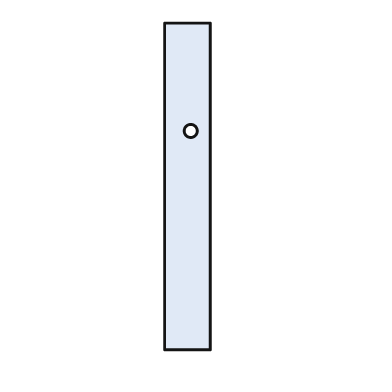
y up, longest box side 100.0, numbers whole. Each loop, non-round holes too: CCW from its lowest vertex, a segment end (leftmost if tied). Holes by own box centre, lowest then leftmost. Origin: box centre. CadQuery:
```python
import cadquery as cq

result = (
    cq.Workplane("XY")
    .moveTo(-7.0, -50.0)
    .lineTo(7.0, -50.0)
    .lineTo(7.0, 50.0)
    .lineTo(-7.0, 50.0)
    .close()
    .moveTo(1.0, 17.0)
    .circle(2.0)
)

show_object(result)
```